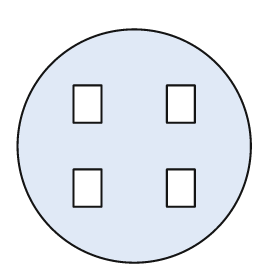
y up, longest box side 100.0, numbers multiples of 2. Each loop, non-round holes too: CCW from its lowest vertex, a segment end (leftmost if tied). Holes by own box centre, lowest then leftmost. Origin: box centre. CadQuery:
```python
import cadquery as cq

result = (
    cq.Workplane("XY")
    .moveTo(0.0, 0.0)
    .circle(50.0)
    .moveTo(-26.0, -26.0)
    .lineTo(-14.0, -26.0)
    .lineTo(-14.0, -10.0)
    .lineTo(-26.0, -10.0)
    .close()
    .moveTo(14.0, -26.0)
    .lineTo(26.0, -26.0)
    .lineTo(26.0, -10.0)
    .lineTo(14.0, -10.0)
    .close()
    .moveTo(-26.0, 10.0)
    .lineTo(-14.0, 10.0)
    .lineTo(-14.0, 26.0)
    .lineTo(-26.0, 26.0)
    .close()
    .moveTo(14.0, 10.0)
    .lineTo(26.0, 10.0)
    .lineTo(26.0, 26.0)
    .lineTo(14.0, 26.0)
    .close()
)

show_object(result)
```